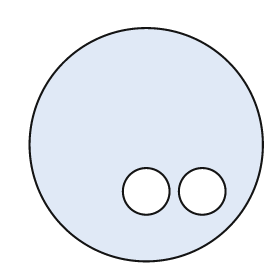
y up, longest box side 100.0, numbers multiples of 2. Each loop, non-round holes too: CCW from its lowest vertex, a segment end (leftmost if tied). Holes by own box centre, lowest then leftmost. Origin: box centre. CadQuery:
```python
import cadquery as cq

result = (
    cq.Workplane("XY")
    .moveTo(0.0, 0.0)
    .circle(50.0)
    .moveTo(0.0, -20.0)
    .circle(10.0)
    .moveTo(24.0, -20.0)
    .circle(10.0)
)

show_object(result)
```